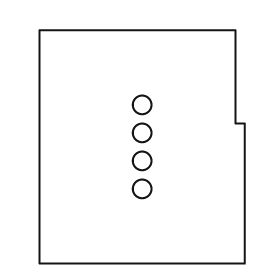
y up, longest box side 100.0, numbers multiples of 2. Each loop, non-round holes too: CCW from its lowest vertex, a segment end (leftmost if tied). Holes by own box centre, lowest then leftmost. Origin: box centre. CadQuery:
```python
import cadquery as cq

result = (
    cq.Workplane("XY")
    .moveTo(-44.0, -50.0)
    .lineTo(44.0, -50.0)
    .lineTo(44.0, 10.0)
    .lineTo(40.0, 10.0)
    .lineTo(40.0, 50.0)
    .lineTo(-44.0, 50.0)
    .close()
    .moveTo(0.0, -18.0)
    .circle(4.0)
    .moveTo(0.0, -6.0)
    .circle(4.0)
    .moveTo(0.0, 6.0)
    .circle(4.0)
    .moveTo(0.0, 18.0)
    .circle(4.0)
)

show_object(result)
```